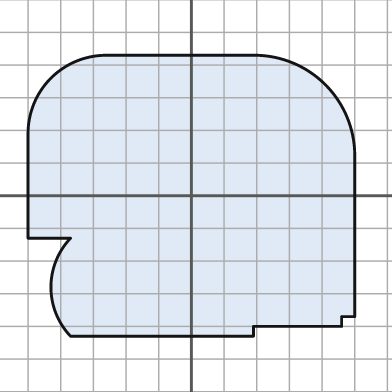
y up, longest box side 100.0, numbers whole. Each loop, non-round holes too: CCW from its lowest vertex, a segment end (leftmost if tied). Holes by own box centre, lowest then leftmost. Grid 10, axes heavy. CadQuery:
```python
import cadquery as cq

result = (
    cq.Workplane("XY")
    .moveTo(-37.0, -43.0)
    .lineTo(19.0, -43.0)
    .lineTo(19.0, -40.0)
    .lineTo(46.0, -40.0)
    .lineTo(46.0, -37.0)
    .lineTo(50.0, -37.0)
    .lineTo(50.0, 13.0)
    .threePointArc((41.0, 34.0), (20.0, 43.0))
    .lineTo(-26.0, 43.0)
    .threePointArc((-43.0, 36.0), (-50.0, 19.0))
    .lineTo(-50.0, -13.0)
    .lineTo(-37.0, -13.0)
    .threePointArc((-43.0, -28.0), (-37.0, -43.0))
    .close()
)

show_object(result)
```